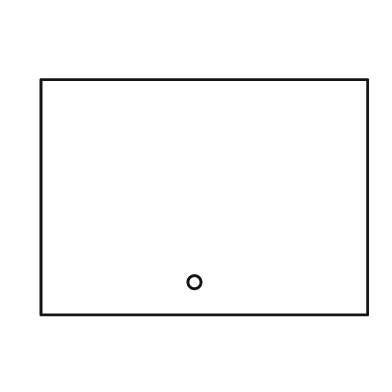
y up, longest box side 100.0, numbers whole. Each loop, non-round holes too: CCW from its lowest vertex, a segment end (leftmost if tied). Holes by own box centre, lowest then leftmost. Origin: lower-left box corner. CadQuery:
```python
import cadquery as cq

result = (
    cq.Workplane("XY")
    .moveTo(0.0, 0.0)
    .lineTo(100.0, 0.0)
    .lineTo(100.0, 72.0)
    .lineTo(0.0, 72.0)
    .close()
    .moveTo(47.0, 10.0)
    .circle(2.0)
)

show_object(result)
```